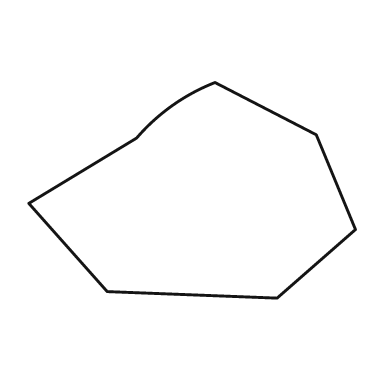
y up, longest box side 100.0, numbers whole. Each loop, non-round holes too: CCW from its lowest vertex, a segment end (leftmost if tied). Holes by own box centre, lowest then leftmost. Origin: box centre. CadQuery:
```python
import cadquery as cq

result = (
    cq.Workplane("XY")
    .moveTo(26.0, -33.0)
    .lineTo(50.0, -12.0)
    .lineTo(38.0, 17.0)
    .lineTo(7.0, 33.0)
    .threePointArc((-6.0, 26.0), (-17.0, 16.0))
    .lineTo(-50.0, -4.0)
    .lineTo(-26.0, -31.0)
    .close()
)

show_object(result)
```